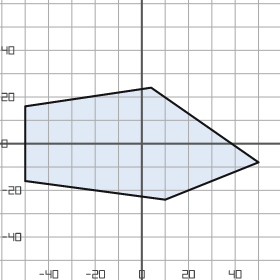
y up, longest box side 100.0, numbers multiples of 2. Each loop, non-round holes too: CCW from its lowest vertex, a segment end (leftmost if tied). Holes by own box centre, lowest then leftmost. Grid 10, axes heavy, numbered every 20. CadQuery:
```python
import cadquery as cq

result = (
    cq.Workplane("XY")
    .moveTo(10.0, -24.0)
    .lineTo(50.0, -8.0)
    .lineTo(4.0, 24.0)
    .lineTo(-50.0, 16.0)
    .lineTo(-50.0, -16.0)
    .close()
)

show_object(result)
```